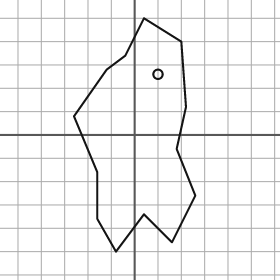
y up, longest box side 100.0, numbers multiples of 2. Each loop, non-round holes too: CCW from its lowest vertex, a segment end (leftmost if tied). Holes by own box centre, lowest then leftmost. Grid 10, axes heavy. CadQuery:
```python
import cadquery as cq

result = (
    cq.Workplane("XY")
    .moveTo(-8.0, -50.0)
    .lineTo(4.0, -34.0)
    .lineTo(16.0, -46.0)
    .lineTo(26.0, -26.0)
    .lineTo(18.0, -6.0)
    .lineTo(22.0, 12.0)
    .lineTo(20.0, 40.0)
    .lineTo(4.0, 50.0)
    .lineTo(-4.0, 34.0)
    .lineTo(-12.0, 28.0)
    .lineTo(-26.0, 8.0)
    .lineTo(-16.0, -16.0)
    .lineTo(-16.0, -36.0)
    .close()
    .moveTo(10.0, 26.0)
    .circle(2.0)
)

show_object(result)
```